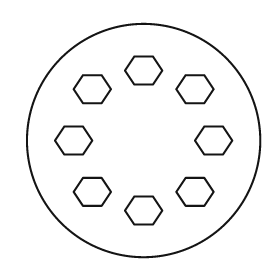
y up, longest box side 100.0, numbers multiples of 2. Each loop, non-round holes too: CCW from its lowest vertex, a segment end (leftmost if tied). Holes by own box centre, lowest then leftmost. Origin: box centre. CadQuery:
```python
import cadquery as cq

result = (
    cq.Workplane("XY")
    .moveTo(0.0, 0.0)
    .circle(50.0)
    .moveTo(-4.0, -36.0)
    .lineTo(4.0, -36.0)
    .lineTo(8.0, -30.0)
    .lineTo(4.0, -24.0)
    .lineTo(-4.0, -24.0)
    .lineTo(-8.0, -30.0)
    .close()
    .moveTo(-26.0, -28.0)
    .lineTo(-18.0, -28.0)
    .lineTo(-14.0, -22.0)
    .lineTo(-18.0, -16.0)
    .lineTo(-26.0, -16.0)
    .lineTo(-30.0, -22.0)
    .close()
    .moveTo(18.0, -28.0)
    .lineTo(26.0, -28.0)
    .lineTo(30.0, -22.0)
    .lineTo(26.0, -16.0)
    .lineTo(18.0, -16.0)
    .lineTo(14.0, -22.0)
    .close()
    .moveTo(-34.0, -6.0)
    .lineTo(-26.0, -6.0)
    .lineTo(-22.0, 0.0)
    .lineTo(-26.0, 6.0)
    .lineTo(-34.0, 6.0)
    .lineTo(-38.0, 0.0)
    .close()
    .moveTo(26.0, -6.0)
    .lineTo(34.0, -6.0)
    .lineTo(38.0, 0.0)
    .lineTo(34.0, 6.0)
    .lineTo(26.0, 6.0)
    .lineTo(22.0, 0.0)
    .close()
    .moveTo(-26.0, 16.0)
    .lineTo(-18.0, 16.0)
    .lineTo(-14.0, 22.0)
    .lineTo(-18.0, 28.0)
    .lineTo(-26.0, 28.0)
    .lineTo(-30.0, 22.0)
    .close()
    .moveTo(18.0, 16.0)
    .lineTo(26.0, 16.0)
    .lineTo(30.0, 22.0)
    .lineTo(26.0, 28.0)
    .lineTo(18.0, 28.0)
    .lineTo(14.0, 22.0)
    .close()
    .moveTo(-4.0, 24.0)
    .lineTo(4.0, 24.0)
    .lineTo(8.0, 30.0)
    .lineTo(4.0, 36.0)
    .lineTo(-4.0, 36.0)
    .lineTo(-8.0, 30.0)
    .close()
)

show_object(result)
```